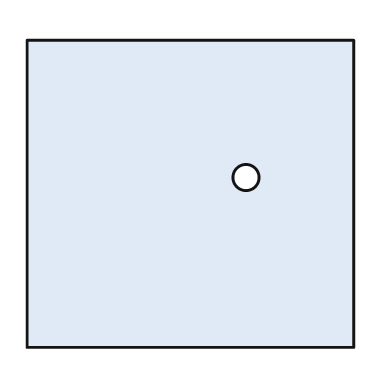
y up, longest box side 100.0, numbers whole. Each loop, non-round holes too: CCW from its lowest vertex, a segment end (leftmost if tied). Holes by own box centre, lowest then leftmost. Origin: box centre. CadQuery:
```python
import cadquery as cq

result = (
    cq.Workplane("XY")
    .moveTo(-50.0, -47.0)
    .lineTo(50.0, -47.0)
    .lineTo(50.0, 47.0)
    .lineTo(-50.0, 47.0)
    .close()
    .moveTo(17.0, 5.0)
    .circle(4.0)
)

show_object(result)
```